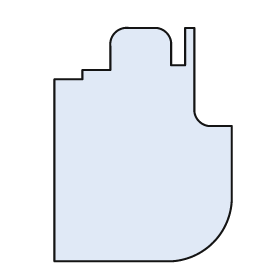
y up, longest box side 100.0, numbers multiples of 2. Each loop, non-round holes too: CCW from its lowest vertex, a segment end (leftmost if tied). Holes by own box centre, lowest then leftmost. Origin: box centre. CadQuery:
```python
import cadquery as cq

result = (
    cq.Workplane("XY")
    .moveTo(-38.0, -50.0)
    .lineTo(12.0, -50.0)
    .threePointArc((30.0, -42.0), (38.0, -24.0))
    .lineTo(38.0, 8.0)
    .lineTo(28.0, 8.0)
    .threePointArc((24.0, 10.0), (22.0, 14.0))
    .lineTo(22.0, 50.0)
    .lineTo(18.0, 50.0)
    .lineTo(18.0, 34.0)
    .lineTo(12.0, 34.0)
    .lineTo(12.0, 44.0)
    .threePointArc((10.0, 48.0), (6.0, 50.0))
    .lineTo(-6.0, 50.0)
    .threePointArc((-12.0, 48.0), (-14.0, 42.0))
    .lineTo(-14.0, 32.0)
    .lineTo(-26.0, 32.0)
    .lineTo(-26.0, 28.0)
    .lineTo(-38.0, 28.0)
    .close()
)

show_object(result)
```